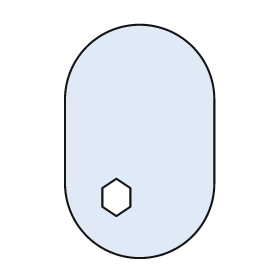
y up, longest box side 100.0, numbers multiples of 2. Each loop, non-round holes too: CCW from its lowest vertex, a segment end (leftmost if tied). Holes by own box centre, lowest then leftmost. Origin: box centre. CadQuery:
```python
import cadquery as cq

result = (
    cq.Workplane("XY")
    .moveTo(-32.0, -18.0)
    .threePointArc((0.0, -50.0), (32.0, -18.0))
    .lineTo(32.0, 18.0)
    .threePointArc((0.0, 50.0), (-32.0, 18.0))
    .close()
    .moveTo(-10.0, -32.0)
    .lineTo(-4.0, -28.0)
    .lineTo(-4.0, -20.0)
    .lineTo(-10.0, -16.0)
    .lineTo(-16.0, -20.0)
    .lineTo(-16.0, -28.0)
    .close()
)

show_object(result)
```